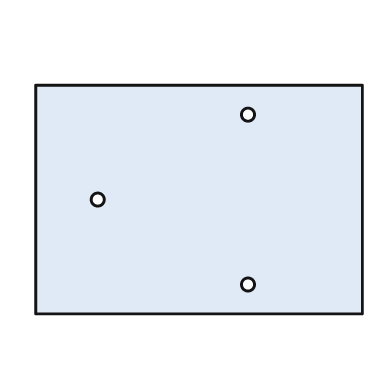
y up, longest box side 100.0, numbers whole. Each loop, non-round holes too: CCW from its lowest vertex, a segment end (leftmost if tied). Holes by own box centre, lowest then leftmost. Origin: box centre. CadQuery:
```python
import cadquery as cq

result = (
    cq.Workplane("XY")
    .moveTo(-50.0, -35.0)
    .lineTo(50.0, -35.0)
    .lineTo(50.0, 35.0)
    .lineTo(-50.0, 35.0)
    .close()
    .moveTo(15.0, -26.0)
    .circle(2.0)
    .moveTo(-31.0, 0.0)
    .circle(2.0)
    .moveTo(15.0, 26.0)
    .circle(2.0)
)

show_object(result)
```